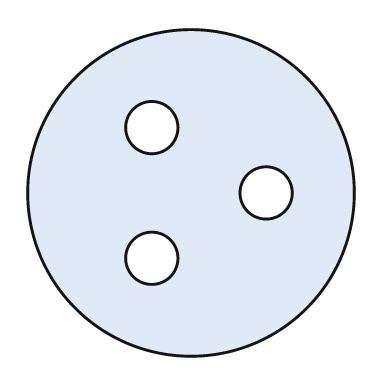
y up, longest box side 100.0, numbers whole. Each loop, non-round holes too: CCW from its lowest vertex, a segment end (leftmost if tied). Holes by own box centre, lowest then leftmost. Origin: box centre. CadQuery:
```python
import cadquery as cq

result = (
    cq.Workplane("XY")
    .moveTo(0.0, 0.0)
    .circle(50.0)
    .moveTo(-12.0, -20.0)
    .circle(8.0)
    .moveTo(23.0, 0.0)
    .circle(8.0)
    .moveTo(-12.0, 20.0)
    .circle(8.0)
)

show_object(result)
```